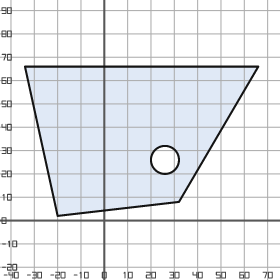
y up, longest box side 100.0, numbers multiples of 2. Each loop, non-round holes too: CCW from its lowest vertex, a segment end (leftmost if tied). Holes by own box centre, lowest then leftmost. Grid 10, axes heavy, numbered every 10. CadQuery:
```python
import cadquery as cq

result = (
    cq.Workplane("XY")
    .moveTo(-20.0, 2.0)
    .lineTo(32.0, 8.0)
    .lineTo(66.0, 66.0)
    .lineTo(-34.0, 66.0)
    .close()
    .moveTo(26.0, 26.0)
    .circle(6.0)
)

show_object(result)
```